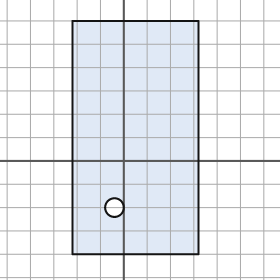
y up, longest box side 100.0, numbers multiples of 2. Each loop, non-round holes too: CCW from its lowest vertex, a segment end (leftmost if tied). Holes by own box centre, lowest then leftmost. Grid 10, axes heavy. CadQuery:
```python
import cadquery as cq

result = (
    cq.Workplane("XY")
    .moveTo(-22.0, -40.0)
    .lineTo(32.0, -40.0)
    .lineTo(32.0, 60.0)
    .lineTo(-22.0, 60.0)
    .close()
    .moveTo(-4.0, -20.0)
    .circle(4.0)
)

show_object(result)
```